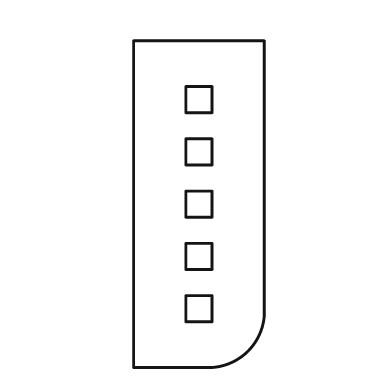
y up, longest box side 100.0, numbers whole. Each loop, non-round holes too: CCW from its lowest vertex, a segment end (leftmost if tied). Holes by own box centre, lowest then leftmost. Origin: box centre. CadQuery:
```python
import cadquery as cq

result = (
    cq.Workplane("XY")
    .moveTo(-20.0, -50.0)
    .lineTo(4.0, -50.0)
    .threePointArc((15.0, -45.0), (20.0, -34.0))
    .lineTo(20.0, 50.0)
    .lineTo(-20.0, 50.0)
    .close()
    .moveTo(-4.0, -36.0)
    .lineTo(4.0, -36.0)
    .lineTo(4.0, -28.0)
    .lineTo(-4.0, -28.0)
    .close()
    .moveTo(-4.0, -20.0)
    .lineTo(4.0, -20.0)
    .lineTo(4.0, -12.0)
    .lineTo(-4.0, -12.0)
    .close()
    .moveTo(-4.0, -4.0)
    .lineTo(4.0, -4.0)
    .lineTo(4.0, 4.0)
    .lineTo(-4.0, 4.0)
    .close()
    .moveTo(-4.0, 12.0)
    .lineTo(4.0, 12.0)
    .lineTo(4.0, 20.0)
    .lineTo(-4.0, 20.0)
    .close()
    .moveTo(-4.0, 28.0)
    .lineTo(4.0, 28.0)
    .lineTo(4.0, 36.0)
    .lineTo(-4.0, 36.0)
    .close()
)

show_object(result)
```